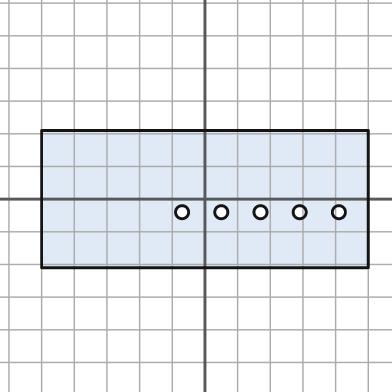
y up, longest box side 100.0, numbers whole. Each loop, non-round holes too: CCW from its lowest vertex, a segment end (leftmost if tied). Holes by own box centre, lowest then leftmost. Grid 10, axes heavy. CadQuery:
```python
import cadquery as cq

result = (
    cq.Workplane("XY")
    .moveTo(-50.0, -21.0)
    .lineTo(50.0, -21.0)
    .lineTo(50.0, 21.0)
    .lineTo(-50.0, 21.0)
    .close()
    .moveTo(-7.0, -4.0)
    .circle(2.0)
    .moveTo(5.0, -4.0)
    .circle(2.0)
    .moveTo(17.0, -4.0)
    .circle(2.0)
    .moveTo(29.0, -4.0)
    .circle(2.0)
    .moveTo(41.0, -4.0)
    .circle(2.0)
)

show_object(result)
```